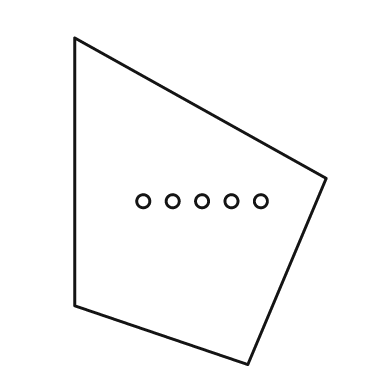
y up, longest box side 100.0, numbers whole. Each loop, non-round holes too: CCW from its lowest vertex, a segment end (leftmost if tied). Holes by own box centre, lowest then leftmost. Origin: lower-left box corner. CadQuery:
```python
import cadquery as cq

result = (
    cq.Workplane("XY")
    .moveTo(53.0, 0.0)
    .lineTo(77.0, 57.0)
    .lineTo(0.0, 100.0)
    .lineTo(0.0, 18.0)
    .close()
    .moveTo(21.0, 50.0)
    .circle(2.0)
    .moveTo(30.0, 50.0)
    .circle(2.0)
    .moveTo(39.0, 50.0)
    .circle(2.0)
    .moveTo(48.0, 50.0)
    .circle(2.0)
    .moveTo(57.0, 50.0)
    .circle(2.0)
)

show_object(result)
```